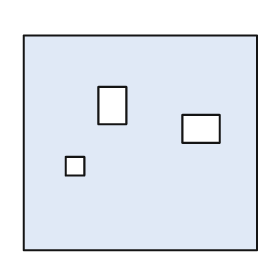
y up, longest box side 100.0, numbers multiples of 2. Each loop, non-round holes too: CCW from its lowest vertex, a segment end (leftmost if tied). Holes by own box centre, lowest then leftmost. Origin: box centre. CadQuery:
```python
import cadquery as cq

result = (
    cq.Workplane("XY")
    .moveTo(-50.0, -46.0)
    .lineTo(50.0, -46.0)
    .lineTo(50.0, 46.0)
    .lineTo(-50.0, 46.0)
    .close()
    .moveTo(-32.0, -14.0)
    .lineTo(-24.0, -14.0)
    .lineTo(-24.0, -6.0)
    .lineTo(-32.0, -6.0)
    .close()
    .moveTo(18.0, 0.0)
    .lineTo(34.0, 0.0)
    .lineTo(34.0, 12.0)
    .lineTo(18.0, 12.0)
    .close()
    .moveTo(-18.0, 8.0)
    .lineTo(-6.0, 8.0)
    .lineTo(-6.0, 24.0)
    .lineTo(-18.0, 24.0)
    .close()
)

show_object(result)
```